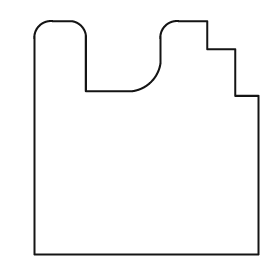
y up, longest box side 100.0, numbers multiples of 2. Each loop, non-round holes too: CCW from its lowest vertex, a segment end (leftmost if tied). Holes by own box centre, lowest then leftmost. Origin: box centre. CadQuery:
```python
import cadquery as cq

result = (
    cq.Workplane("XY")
    .moveTo(-48.0, -50.0)
    .lineTo(48.0, -50.0)
    .lineTo(48.0, 18.0)
    .lineTo(38.0, 18.0)
    .lineTo(38.0, 38.0)
    .lineTo(26.0, 38.0)
    .lineTo(26.0, 50.0)
    .lineTo(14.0, 50.0)
    .threePointArc((8.0, 48.0), (6.0, 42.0))
    .lineTo(6.0, 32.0)
    .threePointArc((2.0, 24.0), (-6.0, 20.0))
    .lineTo(-26.0, 20.0)
    .lineTo(-26.0, 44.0)
    .threePointArc((-28.0, 48.0), (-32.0, 50.0))
    .lineTo(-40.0, 50.0)
    .threePointArc((-46.0, 48.0), (-48.0, 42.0))
    .close()
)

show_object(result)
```